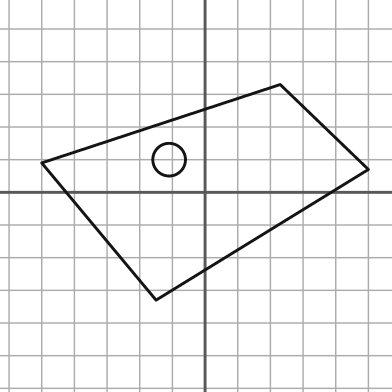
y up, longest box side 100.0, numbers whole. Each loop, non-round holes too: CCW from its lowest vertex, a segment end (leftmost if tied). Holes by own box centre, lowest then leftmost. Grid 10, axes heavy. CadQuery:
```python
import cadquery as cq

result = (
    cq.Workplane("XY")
    .moveTo(-15.0, -33.0)
    .lineTo(50.0, 7.0)
    .lineTo(23.0, 33.0)
    .lineTo(-50.0, 9.0)
    .close()
    .moveTo(-11.0, 10.0)
    .circle(5.0)
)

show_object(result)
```